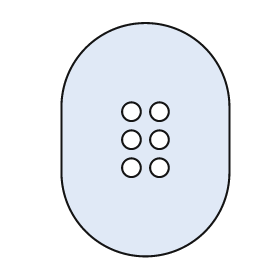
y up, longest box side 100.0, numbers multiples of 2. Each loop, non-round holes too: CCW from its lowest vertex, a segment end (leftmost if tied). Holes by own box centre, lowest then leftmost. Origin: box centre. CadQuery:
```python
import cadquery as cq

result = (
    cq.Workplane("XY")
    .moveTo(-36.0, -14.0)
    .threePointArc((0.0, -50.0), (36.0, -14.0))
    .lineTo(36.0, 14.0)
    .threePointArc((0.0, 50.0), (-36.0, 14.0))
    .close()
    .moveTo(-6.0, -12.0)
    .circle(4.0)
    .moveTo(6.0, -12.0)
    .circle(4.0)
    .moveTo(-6.0, 0.0)
    .circle(4.0)
    .moveTo(6.0, 0.0)
    .circle(4.0)
    .moveTo(-6.0, 12.0)
    .circle(4.0)
    .moveTo(6.0, 12.0)
    .circle(4.0)
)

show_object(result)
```